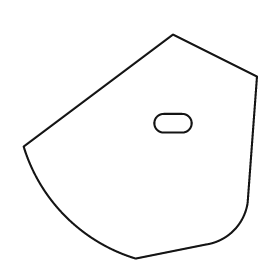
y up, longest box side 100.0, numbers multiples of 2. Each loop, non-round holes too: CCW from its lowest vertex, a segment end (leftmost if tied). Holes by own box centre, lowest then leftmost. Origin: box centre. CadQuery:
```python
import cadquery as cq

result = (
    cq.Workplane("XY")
    .moveTo(-2.0, -48.0)
    .lineTo(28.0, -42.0)
    .threePointArc((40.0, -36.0), (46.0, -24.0))
    .lineTo(50.0, 30.0)
    .lineTo(14.0, 48.0)
    .lineTo(-50.0, 0.0)
    .threePointArc((-32.0, -30.0), (-2.0, -48.0))
    .close()
    .moveTo(10.0, 6.0)
    .lineTo(18.0, 6.0)
    .threePointArc((22.0, 10.0), (18.0, 14.0))
    .lineTo(10.0, 14.0)
    .threePointArc((6.0, 10.0), (10.0, 6.0))
    .close()
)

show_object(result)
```